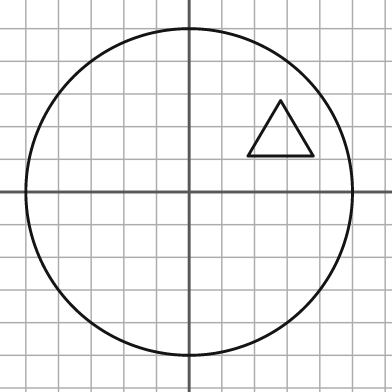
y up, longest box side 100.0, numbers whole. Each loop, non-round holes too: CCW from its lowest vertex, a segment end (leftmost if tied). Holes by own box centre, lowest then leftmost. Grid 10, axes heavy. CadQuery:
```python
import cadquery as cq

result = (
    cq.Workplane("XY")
    .moveTo(0.0, 0.0)
    .circle(50.0)
    .moveTo(18.0, 11.0)
    .lineTo(38.0, 11.0)
    .lineTo(28.0, 28.0)
    .close()
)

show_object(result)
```